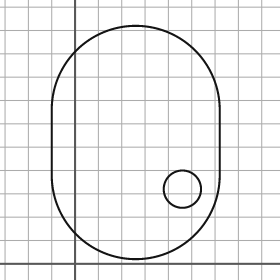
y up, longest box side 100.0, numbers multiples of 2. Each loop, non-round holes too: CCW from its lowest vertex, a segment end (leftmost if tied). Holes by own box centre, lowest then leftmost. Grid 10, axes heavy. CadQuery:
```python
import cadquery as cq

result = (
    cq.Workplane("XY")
    .moveTo(-10.0, 38.0)
    .threePointArc((26.0, 2.0), (62.0, 38.0))
    .lineTo(62.0, 66.0)
    .threePointArc((26.0, 102.0), (-10.0, 66.0))
    .close()
    .moveTo(46.0, 32.0)
    .circle(8.0)
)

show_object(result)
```